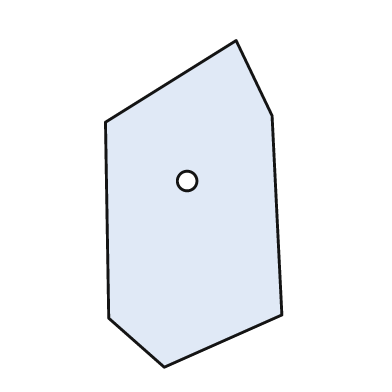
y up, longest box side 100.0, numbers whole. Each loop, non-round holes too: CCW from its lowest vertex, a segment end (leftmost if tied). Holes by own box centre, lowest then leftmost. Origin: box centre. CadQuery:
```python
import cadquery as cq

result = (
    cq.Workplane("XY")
    .moveTo(-9.0, -50.0)
    .lineTo(27.0, -34.0)
    .lineTo(24.0, 27.0)
    .lineTo(13.0, 50.0)
    .lineTo(-27.0, 25.0)
    .lineTo(-26.0, -35.0)
    .close()
    .moveTo(-2.0, 7.0)
    .circle(3.0)
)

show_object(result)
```